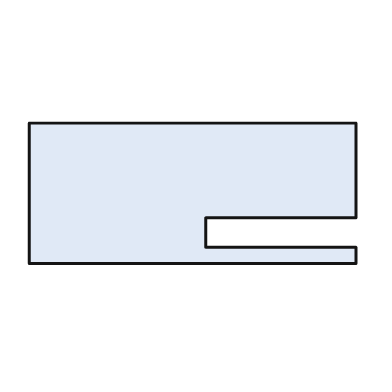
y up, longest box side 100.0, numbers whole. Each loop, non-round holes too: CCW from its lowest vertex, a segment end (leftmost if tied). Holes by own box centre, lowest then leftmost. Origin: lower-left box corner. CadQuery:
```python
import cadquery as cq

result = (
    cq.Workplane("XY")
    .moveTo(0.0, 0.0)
    .lineTo(100.0, 0.0)
    .lineTo(100.0, 5.0)
    .lineTo(54.0, 5.0)
    .lineTo(54.0, 14.0)
    .lineTo(100.0, 14.0)
    .lineTo(100.0, 43.0)
    .lineTo(0.0, 43.0)
    .close()
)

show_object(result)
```